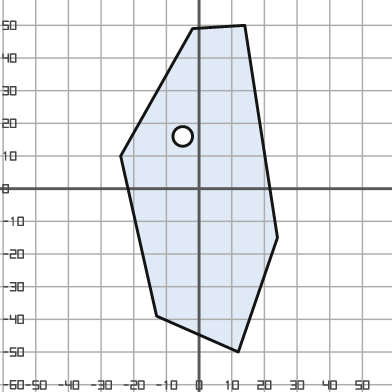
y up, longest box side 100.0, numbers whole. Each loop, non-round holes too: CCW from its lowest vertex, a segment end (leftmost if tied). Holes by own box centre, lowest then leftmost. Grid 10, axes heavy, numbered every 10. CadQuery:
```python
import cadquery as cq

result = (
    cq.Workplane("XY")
    .moveTo(12.0, -50.0)
    .lineTo(24.0, -15.0)
    .lineTo(14.0, 50.0)
    .lineTo(-2.0, 49.0)
    .lineTo(-24.0, 10.0)
    .lineTo(-13.0, -39.0)
    .close()
    .moveTo(-5.0, 16.0)
    .circle(3.0)
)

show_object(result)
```